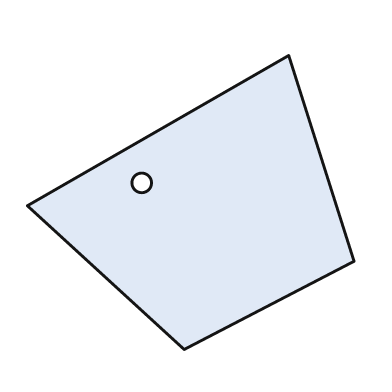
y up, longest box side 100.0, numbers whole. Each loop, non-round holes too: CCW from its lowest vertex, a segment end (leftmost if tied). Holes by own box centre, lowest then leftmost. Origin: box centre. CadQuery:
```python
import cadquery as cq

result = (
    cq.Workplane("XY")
    .moveTo(-2.0, -45.0)
    .lineTo(50.0, -18.0)
    .lineTo(30.0, 45.0)
    .lineTo(-50.0, -1.0)
    .close()
    .moveTo(-15.0, 6.0)
    .circle(3.0)
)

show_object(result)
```